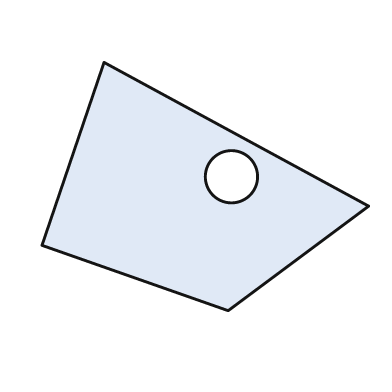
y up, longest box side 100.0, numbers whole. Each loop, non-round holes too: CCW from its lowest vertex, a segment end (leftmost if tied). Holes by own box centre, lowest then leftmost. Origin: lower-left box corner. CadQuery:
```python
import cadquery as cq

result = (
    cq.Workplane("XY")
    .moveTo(57.0, 0.0)
    .lineTo(100.0, 32.0)
    .lineTo(19.0, 76.0)
    .lineTo(0.0, 20.0)
    .close()
    .moveTo(58.0, 41.0)
    .circle(8.0)
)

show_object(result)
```